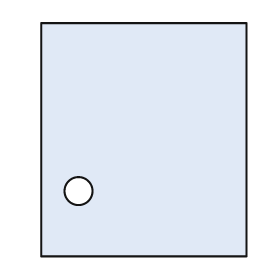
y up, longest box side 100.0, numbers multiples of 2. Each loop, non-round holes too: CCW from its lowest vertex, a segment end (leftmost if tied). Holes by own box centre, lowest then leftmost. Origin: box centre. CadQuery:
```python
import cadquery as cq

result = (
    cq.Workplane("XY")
    .moveTo(-44.0, -50.0)
    .lineTo(44.0, -50.0)
    .lineTo(44.0, 50.0)
    .lineTo(-44.0, 50.0)
    .close()
    .moveTo(-28.0, -22.0)
    .circle(6.0)
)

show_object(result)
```